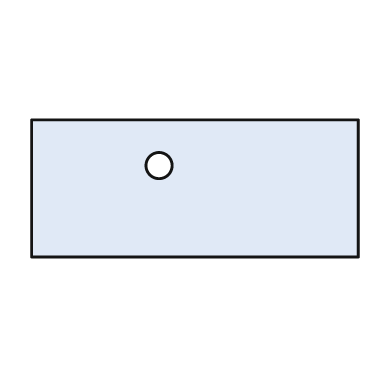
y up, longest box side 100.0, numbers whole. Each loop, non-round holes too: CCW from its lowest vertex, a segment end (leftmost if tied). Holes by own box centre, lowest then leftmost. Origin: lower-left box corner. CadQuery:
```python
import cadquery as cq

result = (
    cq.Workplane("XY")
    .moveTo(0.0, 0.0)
    .lineTo(100.0, 0.0)
    .lineTo(100.0, 42.0)
    .lineTo(0.0, 42.0)
    .close()
    .moveTo(39.0, 28.0)
    .circle(4.0)
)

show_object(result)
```